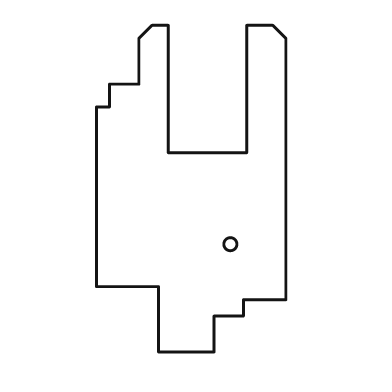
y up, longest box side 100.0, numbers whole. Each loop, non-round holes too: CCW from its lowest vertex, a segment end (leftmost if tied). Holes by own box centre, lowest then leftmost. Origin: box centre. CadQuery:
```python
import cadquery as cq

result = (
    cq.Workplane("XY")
    .moveTo(-10.0, -50.0)
    .lineTo(7.0, -50.0)
    .lineTo(7.0, -39.0)
    .lineTo(16.0, -39.0)
    .lineTo(16.0, -34.0)
    .lineTo(29.0, -34.0)
    .lineTo(29.0, 46.0)
    .lineTo(25.0, 50.0)
    .lineTo(17.0, 50.0)
    .lineTo(17.0, 11.0)
    .lineTo(-7.0, 11.0)
    .lineTo(-7.0, 50.0)
    .lineTo(-12.0, 50.0)
    .lineTo(-16.0, 46.0)
    .lineTo(-16.0, 32.0)
    .lineTo(-25.0, 32.0)
    .lineTo(-25.0, 25.0)
    .lineTo(-29.0, 25.0)
    .lineTo(-29.0, -30.0)
    .lineTo(-10.0, -30.0)
    .close()
    .moveTo(12.0, -17.0)
    .circle(2.0)
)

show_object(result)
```